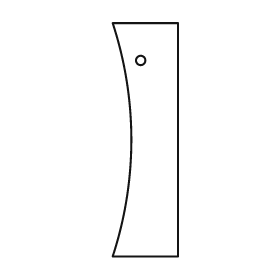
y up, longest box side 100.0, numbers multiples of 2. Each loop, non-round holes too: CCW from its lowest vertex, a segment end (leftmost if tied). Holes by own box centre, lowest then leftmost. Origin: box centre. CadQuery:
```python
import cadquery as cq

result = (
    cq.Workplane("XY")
    .moveTo(-14.0, -50.0)
    .lineTo(14.0, -50.0)
    .lineTo(14.0, 50.0)
    .lineTo(-14.0, 50.0)
    .threePointArc((-6.0, 0.0), (-14.0, -50.0))
    .close()
    .moveTo(-2.0, 34.0)
    .circle(2.0)
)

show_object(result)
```